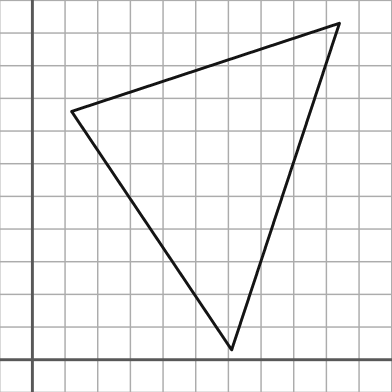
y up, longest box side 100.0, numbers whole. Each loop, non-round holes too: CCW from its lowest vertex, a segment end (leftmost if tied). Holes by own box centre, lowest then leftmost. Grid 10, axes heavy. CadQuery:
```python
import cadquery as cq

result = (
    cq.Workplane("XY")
    .moveTo(61.0, 3.0)
    .lineTo(94.0, 103.0)
    .lineTo(12.0, 76.0)
    .close()
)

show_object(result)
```